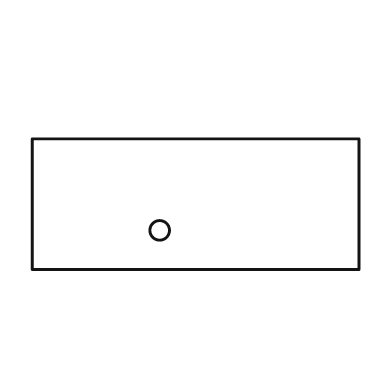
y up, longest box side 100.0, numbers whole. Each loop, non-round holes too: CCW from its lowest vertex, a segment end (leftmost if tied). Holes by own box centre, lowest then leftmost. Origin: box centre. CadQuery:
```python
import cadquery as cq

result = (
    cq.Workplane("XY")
    .moveTo(-50.0, -20.0)
    .lineTo(50.0, -20.0)
    .lineTo(50.0, 20.0)
    .lineTo(-50.0, 20.0)
    .close()
    .moveTo(-11.0, -8.0)
    .circle(3.0)
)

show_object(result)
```